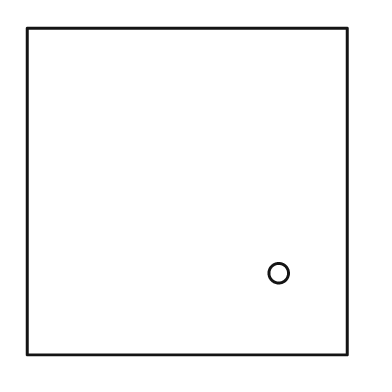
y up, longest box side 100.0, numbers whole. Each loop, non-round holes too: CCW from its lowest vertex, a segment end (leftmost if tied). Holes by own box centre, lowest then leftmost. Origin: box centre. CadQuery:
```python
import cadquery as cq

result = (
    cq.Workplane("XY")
    .moveTo(-49.0, -50.0)
    .lineTo(49.0, -50.0)
    .lineTo(49.0, 50.0)
    .lineTo(-49.0, 50.0)
    .close()
    .moveTo(28.0, -25.0)
    .circle(3.0)
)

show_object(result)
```